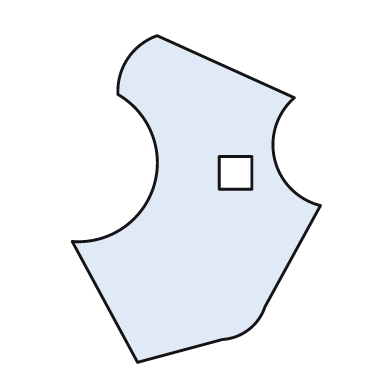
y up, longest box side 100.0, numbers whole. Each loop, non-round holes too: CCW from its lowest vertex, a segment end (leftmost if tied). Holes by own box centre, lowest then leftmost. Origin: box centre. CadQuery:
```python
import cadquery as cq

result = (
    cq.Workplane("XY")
    .moveTo(-18.0, -50.0)
    .lineTo(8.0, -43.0)
    .threePointArc((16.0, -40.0), (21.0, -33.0))
    .lineTo(38.0, -2.0)
    .threePointArc((24.0, 12.0), (30.0, 31.0))
    .lineTo(-12.0, 50.0)
    .threePointArc((-21.0, 43.0), (-24.0, 32.0))
    .threePointArc((-13.0, 4.0), (-38.0, -13.0))
    .close()
    .moveTo(7.0, 3.0)
    .lineTo(17.0, 3.0)
    .lineTo(17.0, 13.0)
    .lineTo(7.0, 13.0)
    .close()
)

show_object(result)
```